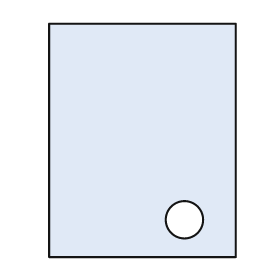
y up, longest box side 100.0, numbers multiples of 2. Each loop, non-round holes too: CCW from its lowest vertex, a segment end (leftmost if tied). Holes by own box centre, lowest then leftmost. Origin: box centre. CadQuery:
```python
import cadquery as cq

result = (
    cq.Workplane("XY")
    .moveTo(-40.0, -50.0)
    .lineTo(40.0, -50.0)
    .lineTo(40.0, 50.0)
    .lineTo(-40.0, 50.0)
    .close()
    .moveTo(18.0, -34.0)
    .circle(8.0)
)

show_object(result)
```